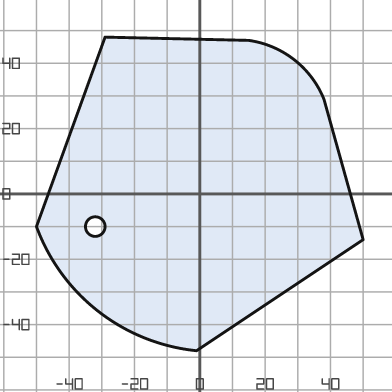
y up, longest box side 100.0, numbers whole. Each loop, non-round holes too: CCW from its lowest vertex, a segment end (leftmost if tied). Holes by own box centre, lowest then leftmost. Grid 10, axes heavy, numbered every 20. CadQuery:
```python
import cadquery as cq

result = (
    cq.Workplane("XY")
    .moveTo(-1.0, -48.0)
    .lineTo(50.0, -14.0)
    .lineTo(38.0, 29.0)
    .threePointArc((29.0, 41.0), (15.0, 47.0))
    .lineTo(-29.0, 48.0)
    .lineTo(-50.0, -10.0)
    .threePointArc((-31.0, -36.0), (-1.0, -48.0))
    .close()
    .moveTo(-32.0, -10.0)
    .circle(3.0)
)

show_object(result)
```